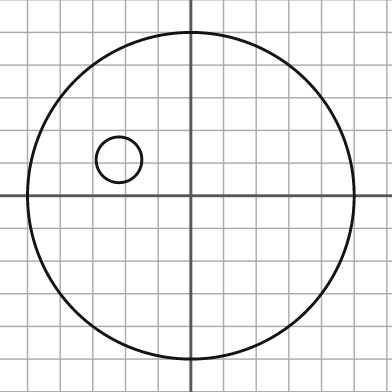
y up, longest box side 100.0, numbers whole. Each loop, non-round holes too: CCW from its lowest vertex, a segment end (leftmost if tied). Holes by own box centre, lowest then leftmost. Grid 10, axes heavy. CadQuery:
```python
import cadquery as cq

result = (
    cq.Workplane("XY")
    .moveTo(0.0, 0.0)
    .circle(50.0)
    .moveTo(-22.0, 11.0)
    .circle(7.0)
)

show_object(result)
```